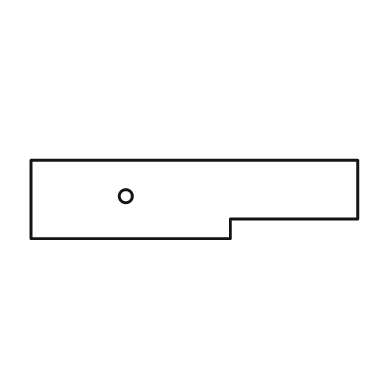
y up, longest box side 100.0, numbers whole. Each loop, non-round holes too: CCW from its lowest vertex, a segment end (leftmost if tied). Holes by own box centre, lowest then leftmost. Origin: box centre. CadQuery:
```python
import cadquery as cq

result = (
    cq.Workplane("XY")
    .moveTo(-50.0, -12.0)
    .lineTo(11.0, -12.0)
    .lineTo(11.0, -6.0)
    .lineTo(50.0, -6.0)
    .lineTo(50.0, 12.0)
    .lineTo(-50.0, 12.0)
    .close()
    .moveTo(-21.0, 1.0)
    .circle(2.0)
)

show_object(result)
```